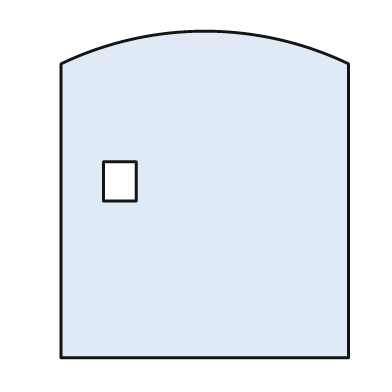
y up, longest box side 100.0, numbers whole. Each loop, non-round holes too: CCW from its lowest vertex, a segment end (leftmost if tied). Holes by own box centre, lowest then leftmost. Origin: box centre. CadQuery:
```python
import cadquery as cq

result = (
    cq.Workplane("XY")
    .moveTo(-44.0, -50.0)
    .lineTo(44.0, -50.0)
    .lineTo(44.0, 40.0)
    .threePointArc((0.0, 50.0), (-44.0, 40.0))
    .close()
    .moveTo(-31.0, -2.0)
    .lineTo(-21.0, -2.0)
    .lineTo(-21.0, 10.0)
    .lineTo(-31.0, 10.0)
    .close()
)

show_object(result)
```